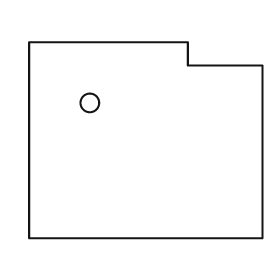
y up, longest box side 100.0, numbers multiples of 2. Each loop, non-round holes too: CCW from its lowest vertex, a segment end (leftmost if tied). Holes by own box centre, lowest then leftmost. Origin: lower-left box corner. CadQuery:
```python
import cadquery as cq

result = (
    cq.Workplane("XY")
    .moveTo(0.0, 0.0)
    .lineTo(100.0, 0.0)
    .lineTo(100.0, 74.0)
    .lineTo(68.0, 74.0)
    .lineTo(68.0, 84.0)
    .lineTo(0.0, 84.0)
    .close()
    .moveTo(26.0, 58.0)
    .circle(4.0)
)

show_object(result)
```